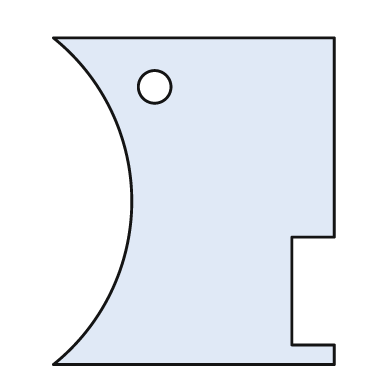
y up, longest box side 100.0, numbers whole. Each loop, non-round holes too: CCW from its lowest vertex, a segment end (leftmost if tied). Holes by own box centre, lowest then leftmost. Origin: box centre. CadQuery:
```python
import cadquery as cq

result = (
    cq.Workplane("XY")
    .moveTo(-43.0, -50.0)
    .lineTo(43.0, -50.0)
    .lineTo(43.0, -44.0)
    .lineTo(30.0, -44.0)
    .lineTo(30.0, -11.0)
    .lineTo(43.0, -11.0)
    .lineTo(43.0, 50.0)
    .lineTo(-43.0, 50.0)
    .threePointArc((-19.0, 0.0), (-43.0, -50.0))
    .close()
    .moveTo(-12.0, 35.0)
    .circle(5.0)
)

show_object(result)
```